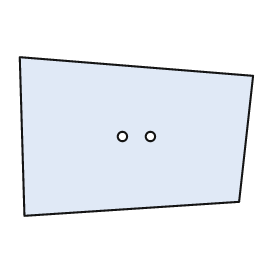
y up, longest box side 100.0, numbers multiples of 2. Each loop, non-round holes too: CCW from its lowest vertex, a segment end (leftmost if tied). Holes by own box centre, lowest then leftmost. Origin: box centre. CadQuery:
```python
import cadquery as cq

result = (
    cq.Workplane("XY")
    .moveTo(-48.0, -34.0)
    .lineTo(44.0, -28.0)
    .lineTo(50.0, 26.0)
    .lineTo(-50.0, 34.0)
    .close()
    .moveTo(-6.0, 0.0)
    .circle(2.0)
    .moveTo(6.0, 0.0)
    .circle(2.0)
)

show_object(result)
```